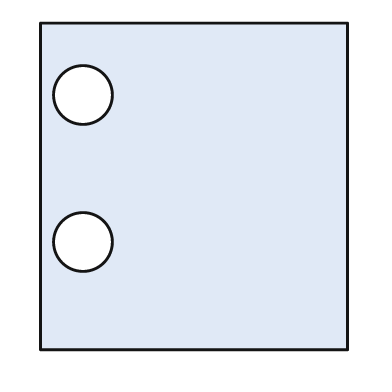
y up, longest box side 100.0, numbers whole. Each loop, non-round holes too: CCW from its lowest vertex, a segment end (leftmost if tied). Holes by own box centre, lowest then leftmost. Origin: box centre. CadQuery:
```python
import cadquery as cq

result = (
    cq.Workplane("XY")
    .moveTo(-47.0, -50.0)
    .lineTo(47.0, -50.0)
    .lineTo(47.0, 50.0)
    .lineTo(-47.0, 50.0)
    .close()
    .moveTo(-34.0, -17.0)
    .circle(9.0)
    .moveTo(-34.0, 28.0)
    .circle(9.0)
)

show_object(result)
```